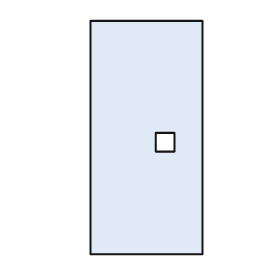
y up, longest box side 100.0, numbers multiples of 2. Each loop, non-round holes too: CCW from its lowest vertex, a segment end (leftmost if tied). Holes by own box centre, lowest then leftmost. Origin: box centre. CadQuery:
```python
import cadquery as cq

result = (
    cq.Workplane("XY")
    .moveTo(-24.0, -50.0)
    .lineTo(24.0, -50.0)
    .lineTo(24.0, 50.0)
    .lineTo(-24.0, 50.0)
    .close()
    .moveTo(4.0, -6.0)
    .lineTo(12.0, -6.0)
    .lineTo(12.0, 2.0)
    .lineTo(4.0, 2.0)
    .close()
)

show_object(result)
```